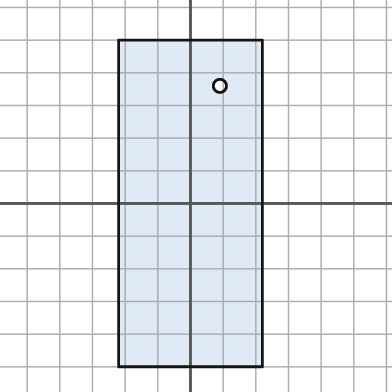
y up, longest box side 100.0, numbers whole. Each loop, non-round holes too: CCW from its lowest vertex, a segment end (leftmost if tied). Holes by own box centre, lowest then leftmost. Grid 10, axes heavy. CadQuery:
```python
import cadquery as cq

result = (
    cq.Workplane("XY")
    .moveTo(-22.0, -50.0)
    .lineTo(22.0, -50.0)
    .lineTo(22.0, 50.0)
    .lineTo(-22.0, 50.0)
    .close()
    .moveTo(9.0, 36.0)
    .circle(2.0)
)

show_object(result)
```